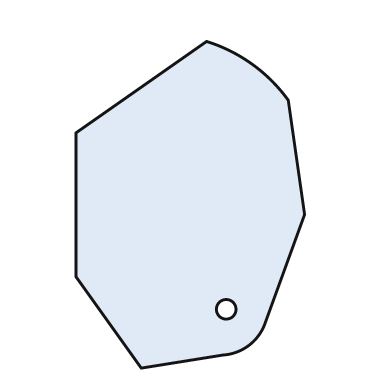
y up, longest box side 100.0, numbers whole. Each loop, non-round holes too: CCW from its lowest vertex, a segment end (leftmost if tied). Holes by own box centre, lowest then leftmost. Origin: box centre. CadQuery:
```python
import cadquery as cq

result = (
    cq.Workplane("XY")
    .moveTo(-15.0, -50.0)
    .lineTo(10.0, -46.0)
    .threePointArc((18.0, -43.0), (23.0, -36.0))
    .lineTo(35.0, -3.0)
    .lineTo(30.0, 32.0)
    .threePointArc((19.0, 43.0), (5.0, 50.0))
    .lineTo(-35.0, 22.0)
    .lineTo(-35.0, -22.0)
    .close()
    .moveTo(11.0, -32.0)
    .circle(3.0)
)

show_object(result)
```